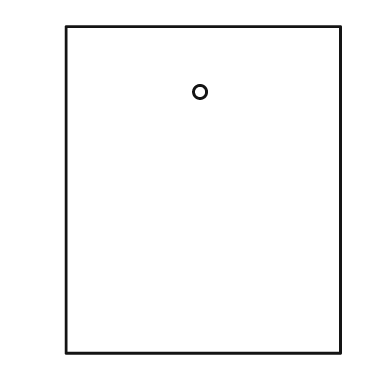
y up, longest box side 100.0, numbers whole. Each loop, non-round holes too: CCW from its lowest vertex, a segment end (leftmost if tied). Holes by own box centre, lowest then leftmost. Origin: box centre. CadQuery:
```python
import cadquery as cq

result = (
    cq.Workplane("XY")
    .moveTo(-42.0, -50.0)
    .lineTo(42.0, -50.0)
    .lineTo(42.0, 50.0)
    .lineTo(-42.0, 50.0)
    .close()
    .moveTo(-1.0, 30.0)
    .circle(2.0)
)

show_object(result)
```